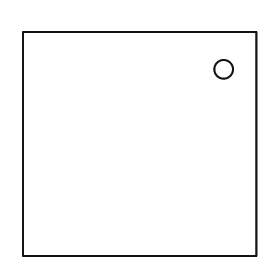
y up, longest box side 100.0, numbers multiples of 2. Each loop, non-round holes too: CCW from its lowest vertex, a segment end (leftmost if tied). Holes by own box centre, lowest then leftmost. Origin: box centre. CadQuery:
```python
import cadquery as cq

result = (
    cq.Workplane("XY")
    .moveTo(-50.0, -48.0)
    .lineTo(50.0, -48.0)
    .lineTo(50.0, 48.0)
    .lineTo(-50.0, 48.0)
    .close()
    .moveTo(36.0, 32.0)
    .circle(4.0)
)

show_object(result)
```